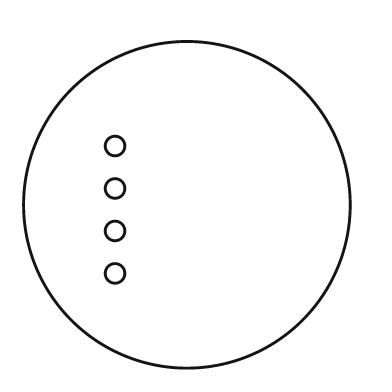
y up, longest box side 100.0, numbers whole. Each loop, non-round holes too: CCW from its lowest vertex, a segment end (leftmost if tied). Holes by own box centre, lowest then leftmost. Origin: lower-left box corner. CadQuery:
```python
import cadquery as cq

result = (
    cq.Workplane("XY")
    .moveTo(50.0, 50.0)
    .circle(50.0)
    .moveTo(28.0, 29.0)
    .circle(3.0)
    .moveTo(28.0, 42.0)
    .circle(3.0)
    .moveTo(28.0, 55.0)
    .circle(3.0)
    .moveTo(28.0, 68.0)
    .circle(3.0)
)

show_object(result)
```